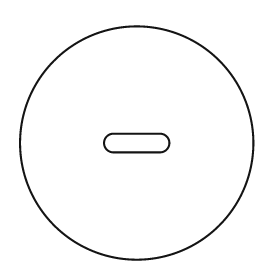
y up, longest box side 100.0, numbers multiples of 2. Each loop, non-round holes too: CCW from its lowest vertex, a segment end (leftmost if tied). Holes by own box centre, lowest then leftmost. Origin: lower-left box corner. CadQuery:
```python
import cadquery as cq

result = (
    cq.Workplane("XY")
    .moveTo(50.0, 50.0)
    .circle(50.0)
    .moveTo(40.0, 46.0)
    .lineTo(60.0, 46.0)
    .threePointArc((64.0, 50.0), (60.0, 54.0))
    .lineTo(40.0, 54.0)
    .threePointArc((36.0, 50.0), (40.0, 46.0))
    .close()
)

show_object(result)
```